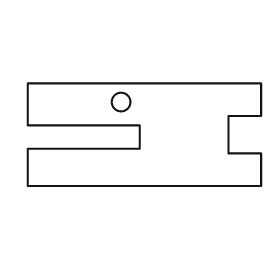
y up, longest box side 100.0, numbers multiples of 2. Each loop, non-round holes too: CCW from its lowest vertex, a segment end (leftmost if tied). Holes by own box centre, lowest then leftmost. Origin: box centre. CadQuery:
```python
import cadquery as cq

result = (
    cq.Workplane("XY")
    .moveTo(-50.0, -22.0)
    .lineTo(50.0, -22.0)
    .lineTo(50.0, -8.0)
    .lineTo(36.0, -8.0)
    .lineTo(36.0, 8.0)
    .lineTo(50.0, 8.0)
    .lineTo(50.0, 22.0)
    .lineTo(-50.0, 22.0)
    .lineTo(-50.0, 4.0)
    .lineTo(-2.0, 4.0)
    .lineTo(-2.0, -6.0)
    .lineTo(-50.0, -6.0)
    .close()
    .moveTo(-10.0, 14.0)
    .circle(4.0)
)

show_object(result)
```